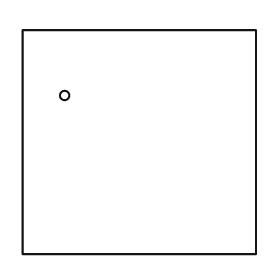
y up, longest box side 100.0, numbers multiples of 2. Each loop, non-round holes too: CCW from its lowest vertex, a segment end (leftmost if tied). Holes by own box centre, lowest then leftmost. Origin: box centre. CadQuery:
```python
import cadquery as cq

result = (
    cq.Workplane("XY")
    .moveTo(-50.0, -48.0)
    .lineTo(50.0, -48.0)
    .lineTo(50.0, 48.0)
    .lineTo(-50.0, 48.0)
    .close()
    .moveTo(-32.0, 20.0)
    .circle(2.0)
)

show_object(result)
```